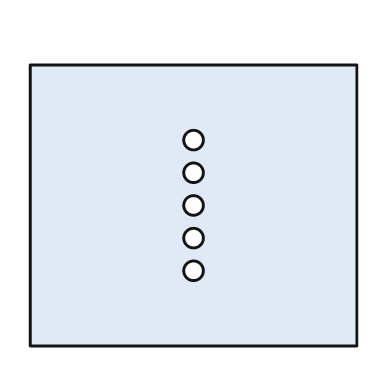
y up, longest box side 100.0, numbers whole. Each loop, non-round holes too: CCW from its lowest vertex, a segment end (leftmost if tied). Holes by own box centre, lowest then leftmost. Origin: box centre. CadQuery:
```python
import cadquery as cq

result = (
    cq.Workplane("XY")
    .moveTo(-50.0, -43.0)
    .lineTo(50.0, -43.0)
    .lineTo(50.0, 43.0)
    .lineTo(-50.0, 43.0)
    .close()
    .moveTo(0.0, -20.0)
    .circle(3.0)
    .moveTo(0.0, -10.0)
    .circle(3.0)
    .moveTo(0.0, 0.0)
    .circle(3.0)
    .moveTo(0.0, 10.0)
    .circle(3.0)
    .moveTo(0.0, 20.0)
    .circle(3.0)
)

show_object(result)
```